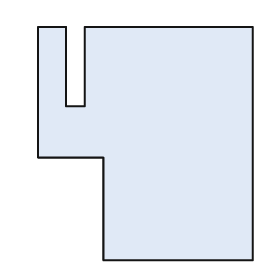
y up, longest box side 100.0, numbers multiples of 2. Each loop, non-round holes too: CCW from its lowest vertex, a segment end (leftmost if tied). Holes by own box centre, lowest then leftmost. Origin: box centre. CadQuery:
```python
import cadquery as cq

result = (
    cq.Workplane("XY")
    .moveTo(-18.0, -50.0)
    .lineTo(46.0, -50.0)
    .lineTo(46.0, 50.0)
    .lineTo(-26.0, 50.0)
    .lineTo(-26.0, 16.0)
    .lineTo(-34.0, 16.0)
    .lineTo(-34.0, 50.0)
    .lineTo(-46.0, 50.0)
    .lineTo(-46.0, -6.0)
    .lineTo(-18.0, -6.0)
    .close()
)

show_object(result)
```